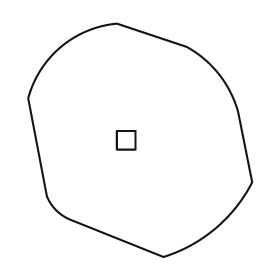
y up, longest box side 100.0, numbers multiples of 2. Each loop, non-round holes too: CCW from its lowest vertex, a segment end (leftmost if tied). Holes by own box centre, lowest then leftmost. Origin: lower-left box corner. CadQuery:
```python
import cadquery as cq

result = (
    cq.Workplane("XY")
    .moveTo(58.0, 0.0)
    .threePointArc((80.0, 12.0), (96.0, 32.0))
    .lineTo(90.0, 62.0)
    .threePointArc((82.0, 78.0), (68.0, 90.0))
    .lineTo(38.0, 100.0)
    .threePointArc((14.0, 90.0), (0.0, 68.0))
    .lineTo(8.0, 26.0)
    .threePointArc((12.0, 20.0), (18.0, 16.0))
    .close()
    .moveTo(38.0, 46.0)
    .lineTo(46.0, 46.0)
    .lineTo(46.0, 54.0)
    .lineTo(38.0, 54.0)
    .close()
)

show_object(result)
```